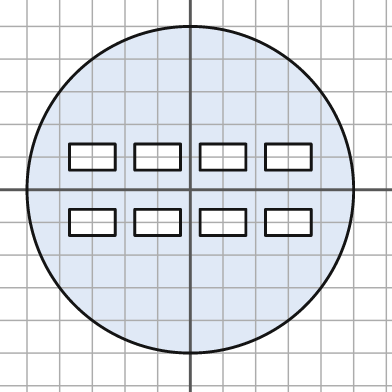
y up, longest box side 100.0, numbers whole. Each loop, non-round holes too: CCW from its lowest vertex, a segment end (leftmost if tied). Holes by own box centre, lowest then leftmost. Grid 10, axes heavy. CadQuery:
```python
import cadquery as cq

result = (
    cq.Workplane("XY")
    .moveTo(0.0, 0.0)
    .circle(50.0)
    .moveTo(-37.0, -14.0)
    .lineTo(-23.0, -14.0)
    .lineTo(-23.0, -6.0)
    .lineTo(-37.0, -6.0)
    .close()
    .moveTo(-17.0, -14.0)
    .lineTo(-3.0, -14.0)
    .lineTo(-3.0, -6.0)
    .lineTo(-17.0, -6.0)
    .close()
    .moveTo(3.0, -14.0)
    .lineTo(17.0, -14.0)
    .lineTo(17.0, -6.0)
    .lineTo(3.0, -6.0)
    .close()
    .moveTo(23.0, -14.0)
    .lineTo(37.0, -14.0)
    .lineTo(37.0, -6.0)
    .lineTo(23.0, -6.0)
    .close()
    .moveTo(-37.0, 6.0)
    .lineTo(-23.0, 6.0)
    .lineTo(-23.0, 14.0)
    .lineTo(-37.0, 14.0)
    .close()
    .moveTo(-17.0, 6.0)
    .lineTo(-3.0, 6.0)
    .lineTo(-3.0, 14.0)
    .lineTo(-17.0, 14.0)
    .close()
    .moveTo(3.0, 6.0)
    .lineTo(17.0, 6.0)
    .lineTo(17.0, 14.0)
    .lineTo(3.0, 14.0)
    .close()
    .moveTo(23.0, 6.0)
    .lineTo(37.0, 6.0)
    .lineTo(37.0, 14.0)
    .lineTo(23.0, 14.0)
    .close()
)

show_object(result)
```